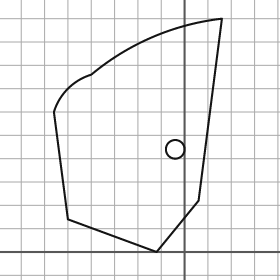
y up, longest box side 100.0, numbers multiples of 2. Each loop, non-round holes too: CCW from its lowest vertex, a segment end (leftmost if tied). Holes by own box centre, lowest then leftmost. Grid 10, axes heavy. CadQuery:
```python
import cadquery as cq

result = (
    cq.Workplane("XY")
    .moveTo(-12.0, 0.0)
    .lineTo(6.0, 22.0)
    .lineTo(16.0, 100.0)
    .threePointArc((-14.0, 92.0), (-40.0, 76.0))
    .threePointArc((-50.0, 70.0), (-56.0, 60.0))
    .lineTo(-50.0, 14.0)
    .close()
    .moveTo(-4.0, 44.0)
    .circle(4.0)
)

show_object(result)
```